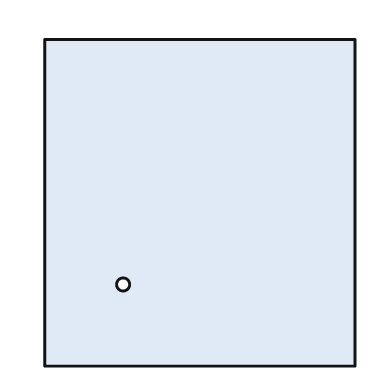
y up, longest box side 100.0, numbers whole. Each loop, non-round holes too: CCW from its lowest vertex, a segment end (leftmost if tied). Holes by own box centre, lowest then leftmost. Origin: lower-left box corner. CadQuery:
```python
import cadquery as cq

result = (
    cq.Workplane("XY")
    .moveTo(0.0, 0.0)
    .lineTo(95.0, 0.0)
    .lineTo(95.0, 100.0)
    .lineTo(0.0, 100.0)
    .close()
    .moveTo(24.0, 25.0)
    .circle(2.0)
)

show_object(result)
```